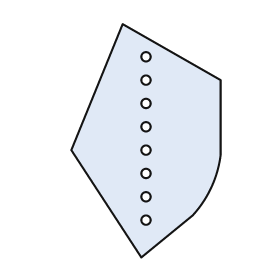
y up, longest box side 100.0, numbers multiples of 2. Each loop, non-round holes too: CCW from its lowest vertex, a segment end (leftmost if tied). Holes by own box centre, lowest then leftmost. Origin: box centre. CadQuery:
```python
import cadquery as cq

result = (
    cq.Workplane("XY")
    .moveTo(-2.0, -50.0)
    .lineTo(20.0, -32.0)
    .threePointArc((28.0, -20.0), (32.0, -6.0))
    .lineTo(32.0, 26.0)
    .lineTo(-10.0, 50.0)
    .lineTo(-32.0, -4.0)
    .close()
    .moveTo(0.0, -34.0)
    .circle(2.0)
    .moveTo(0.0, -24.0)
    .circle(2.0)
    .moveTo(0.0, -14.0)
    .circle(2.0)
    .moveTo(0.0, -4.0)
    .circle(2.0)
    .moveTo(0.0, 6.0)
    .circle(2.0)
    .moveTo(0.0, 16.0)
    .circle(2.0)
    .moveTo(0.0, 26.0)
    .circle(2.0)
    .moveTo(0.0, 36.0)
    .circle(2.0)
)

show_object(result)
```